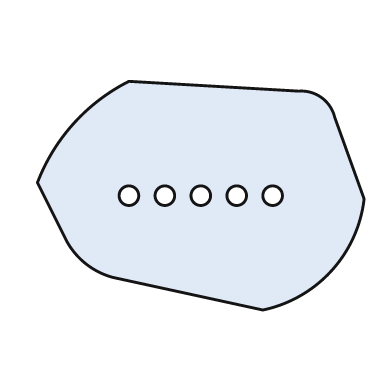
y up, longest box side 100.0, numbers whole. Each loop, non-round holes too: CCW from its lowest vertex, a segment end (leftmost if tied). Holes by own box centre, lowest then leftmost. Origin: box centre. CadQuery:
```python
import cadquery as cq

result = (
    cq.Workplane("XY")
    .moveTo(19.0, -35.0)
    .threePointArc((40.0, -23.0), (50.0, -1.0))
    .lineTo(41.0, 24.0)
    .threePointArc((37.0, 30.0), (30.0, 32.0))
    .lineTo(-22.0, 35.0)
    .threePointArc((-39.0, 22.0), (-50.0, 4.0))
    .lineTo(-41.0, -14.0)
    .threePointArc((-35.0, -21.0), (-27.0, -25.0))
    .close()
    .moveTo(-22.0, 0.0)
    .circle(3.0)
    .moveTo(-11.0, 0.0)
    .circle(3.0)
    .moveTo(0.0, 0.0)
    .circle(3.0)
    .moveTo(11.0, 0.0)
    .circle(3.0)
    .moveTo(22.0, 0.0)
    .circle(3.0)
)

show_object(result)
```